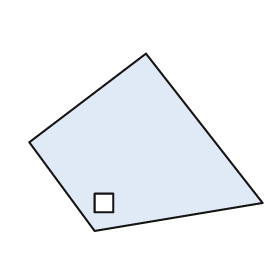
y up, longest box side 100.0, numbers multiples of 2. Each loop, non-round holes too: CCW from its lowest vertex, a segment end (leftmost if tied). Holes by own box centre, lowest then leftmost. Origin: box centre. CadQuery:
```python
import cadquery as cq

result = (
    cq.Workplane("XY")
    .moveTo(-22.0, -38.0)
    .lineTo(50.0, -26.0)
    .lineTo(0.0, 38.0)
    .lineTo(-50.0, 0.0)
    .close()
    .moveTo(-22.0, -30.0)
    .lineTo(-14.0, -30.0)
    .lineTo(-14.0, -22.0)
    .lineTo(-22.0, -22.0)
    .close()
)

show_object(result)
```